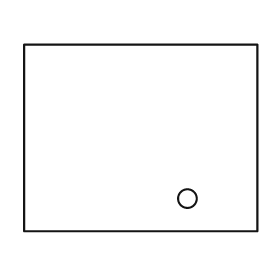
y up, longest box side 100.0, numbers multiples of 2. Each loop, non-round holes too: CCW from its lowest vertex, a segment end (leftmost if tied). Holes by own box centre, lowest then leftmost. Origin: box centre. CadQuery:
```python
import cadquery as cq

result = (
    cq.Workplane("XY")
    .moveTo(-50.0, -40.0)
    .lineTo(50.0, -40.0)
    .lineTo(50.0, 40.0)
    .lineTo(-50.0, 40.0)
    .close()
    .moveTo(20.0, -26.0)
    .circle(4.0)
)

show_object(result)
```